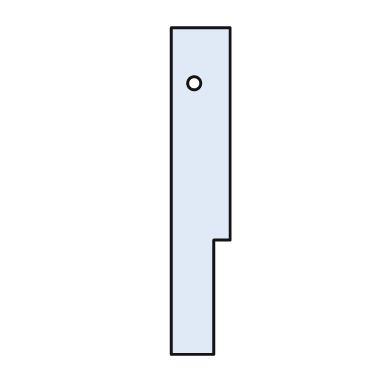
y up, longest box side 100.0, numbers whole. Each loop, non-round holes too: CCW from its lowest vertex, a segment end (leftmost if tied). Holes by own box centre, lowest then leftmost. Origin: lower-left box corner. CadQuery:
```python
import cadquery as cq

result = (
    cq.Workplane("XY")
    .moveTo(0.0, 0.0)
    .lineTo(13.0, 0.0)
    .lineTo(13.0, 35.0)
    .lineTo(18.0, 35.0)
    .lineTo(18.0, 100.0)
    .lineTo(0.0, 100.0)
    .close()
    .moveTo(7.0, 83.0)
    .circle(2.0)
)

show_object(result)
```